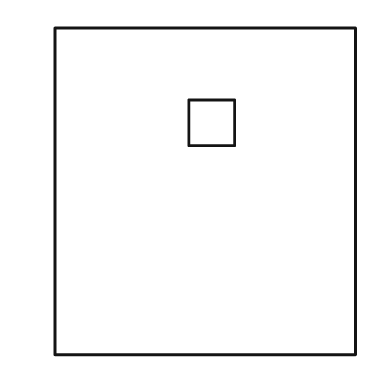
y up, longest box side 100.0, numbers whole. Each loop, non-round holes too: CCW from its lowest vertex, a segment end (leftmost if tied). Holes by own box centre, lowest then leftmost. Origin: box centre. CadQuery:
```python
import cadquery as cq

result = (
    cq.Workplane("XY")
    .moveTo(-46.0, -50.0)
    .lineTo(46.0, -50.0)
    .lineTo(46.0, 50.0)
    .lineTo(-46.0, 50.0)
    .close()
    .moveTo(-5.0, 14.0)
    .lineTo(9.0, 14.0)
    .lineTo(9.0, 28.0)
    .lineTo(-5.0, 28.0)
    .close()
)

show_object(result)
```